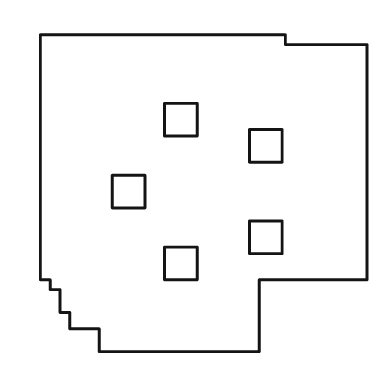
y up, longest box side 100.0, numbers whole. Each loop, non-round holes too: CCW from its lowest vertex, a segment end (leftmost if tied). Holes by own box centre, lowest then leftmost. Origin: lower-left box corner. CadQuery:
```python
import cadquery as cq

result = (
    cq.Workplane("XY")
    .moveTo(18.0, 0.0)
    .lineTo(67.0, 0.0)
    .lineTo(67.0, 22.0)
    .lineTo(100.0, 22.0)
    .lineTo(100.0, 94.0)
    .lineTo(75.0, 94.0)
    .lineTo(75.0, 97.0)
    .lineTo(0.0, 97.0)
    .lineTo(0.0, 22.0)
    .lineTo(3.0, 22.0)
    .lineTo(3.0, 19.0)
    .lineTo(6.0, 19.0)
    .lineTo(6.0, 12.0)
    .lineTo(9.0, 12.0)
    .lineTo(9.0, 7.0)
    .lineTo(18.0, 7.0)
    .close()
    .moveTo(38.0, 22.0)
    .lineTo(48.0, 22.0)
    .lineTo(48.0, 32.0)
    .lineTo(38.0, 32.0)
    .close()
    .moveTo(64.0, 30.0)
    .lineTo(74.0, 30.0)
    .lineTo(74.0, 40.0)
    .lineTo(64.0, 40.0)
    .close()
    .moveTo(22.0, 44.0)
    .lineTo(32.0, 44.0)
    .lineTo(32.0, 54.0)
    .lineTo(22.0, 54.0)
    .close()
    .moveTo(64.0, 58.0)
    .lineTo(74.0, 58.0)
    .lineTo(74.0, 68.0)
    .lineTo(64.0, 68.0)
    .close()
    .moveTo(38.0, 66.0)
    .lineTo(48.0, 66.0)
    .lineTo(48.0, 76.0)
    .lineTo(38.0, 76.0)
    .close()
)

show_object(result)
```